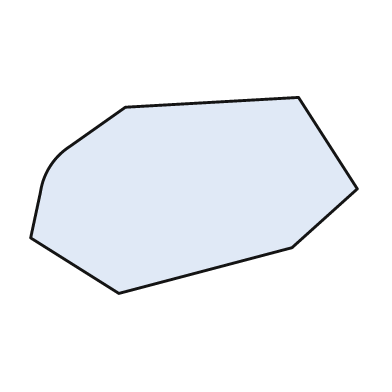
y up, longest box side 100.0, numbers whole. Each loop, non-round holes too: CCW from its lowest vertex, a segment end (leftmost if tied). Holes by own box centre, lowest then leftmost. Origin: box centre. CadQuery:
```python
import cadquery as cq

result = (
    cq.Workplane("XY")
    .moveTo(-23.0, -30.0)
    .lineTo(30.0, -16.0)
    .lineTo(50.0, 2.0)
    .lineTo(32.0, 30.0)
    .lineTo(-21.0, 27.0)
    .lineTo(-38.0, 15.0)
    .threePointArc((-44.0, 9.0), (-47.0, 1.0))
    .lineTo(-50.0, -13.0)
    .close()
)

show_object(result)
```